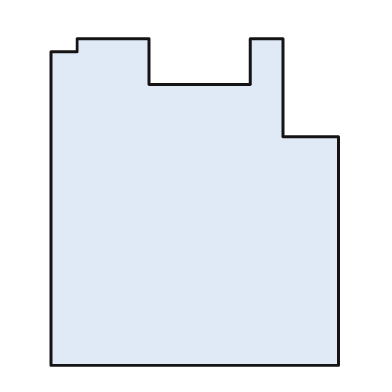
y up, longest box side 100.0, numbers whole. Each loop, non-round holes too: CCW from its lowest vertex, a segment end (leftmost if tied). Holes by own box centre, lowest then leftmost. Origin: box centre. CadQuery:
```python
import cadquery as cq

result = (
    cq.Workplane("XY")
    .moveTo(-44.0, -50.0)
    .lineTo(44.0, -50.0)
    .lineTo(44.0, 20.0)
    .lineTo(27.0, 20.0)
    .lineTo(27.0, 50.0)
    .lineTo(17.0, 50.0)
    .lineTo(17.0, 36.0)
    .lineTo(-14.0, 36.0)
    .lineTo(-14.0, 50.0)
    .lineTo(-36.0, 50.0)
    .lineTo(-36.0, 46.0)
    .lineTo(-44.0, 46.0)
    .close()
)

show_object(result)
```